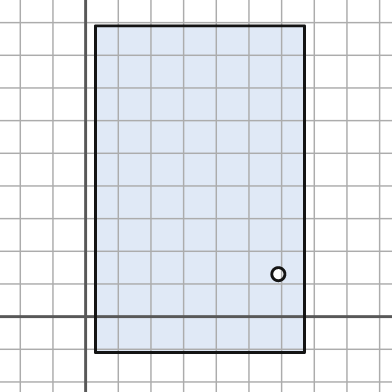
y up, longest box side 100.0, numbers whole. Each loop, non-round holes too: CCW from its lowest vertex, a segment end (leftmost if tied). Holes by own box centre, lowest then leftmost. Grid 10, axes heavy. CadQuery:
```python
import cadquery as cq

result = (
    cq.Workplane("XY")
    .moveTo(3.0, -11.0)
    .lineTo(67.0, -11.0)
    .lineTo(67.0, 89.0)
    .lineTo(3.0, 89.0)
    .close()
    .moveTo(59.0, 13.0)
    .circle(2.0)
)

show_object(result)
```